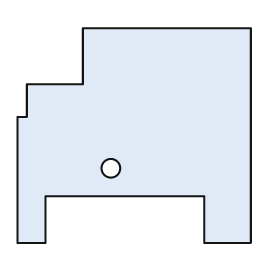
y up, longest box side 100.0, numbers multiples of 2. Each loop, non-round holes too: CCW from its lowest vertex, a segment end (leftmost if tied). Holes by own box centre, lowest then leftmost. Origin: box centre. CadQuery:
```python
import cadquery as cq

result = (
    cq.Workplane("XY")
    .moveTo(-50.0, -46.0)
    .lineTo(-38.0, -46.0)
    .lineTo(-38.0, -26.0)
    .lineTo(30.0, -26.0)
    .lineTo(30.0, -46.0)
    .lineTo(50.0, -46.0)
    .lineTo(50.0, 46.0)
    .lineTo(-22.0, 46.0)
    .lineTo(-22.0, 22.0)
    .lineTo(-46.0, 22.0)
    .lineTo(-46.0, 8.0)
    .lineTo(-50.0, 8.0)
    .close()
    .moveTo(-10.0, -14.0)
    .circle(4.0)
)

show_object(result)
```